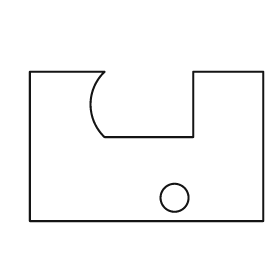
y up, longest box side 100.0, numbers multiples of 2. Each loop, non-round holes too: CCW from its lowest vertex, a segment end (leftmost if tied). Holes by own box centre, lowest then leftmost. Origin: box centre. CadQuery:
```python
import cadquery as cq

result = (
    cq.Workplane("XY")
    .moveTo(-50.0, -32.0)
    .lineTo(50.0, -32.0)
    .lineTo(50.0, 32.0)
    .lineTo(20.0, 32.0)
    .lineTo(20.0, 4.0)
    .lineTo(-18.0, 4.0)
    .threePointArc((-24.0, 18.0), (-18.0, 32.0))
    .lineTo(-50.0, 32.0)
    .close()
    .moveTo(12.0, -22.0)
    .circle(6.0)
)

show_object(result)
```